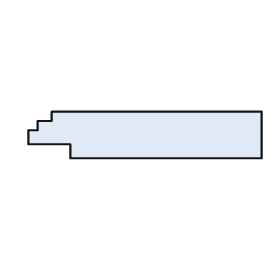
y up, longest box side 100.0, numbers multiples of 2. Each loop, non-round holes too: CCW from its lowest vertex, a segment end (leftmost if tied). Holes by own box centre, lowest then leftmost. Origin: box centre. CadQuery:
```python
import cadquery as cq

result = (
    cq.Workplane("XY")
    .moveTo(-32.0, -10.0)
    .lineTo(50.0, -10.0)
    .lineTo(50.0, 10.0)
    .lineTo(-40.0, 10.0)
    .lineTo(-40.0, 6.0)
    .lineTo(-46.0, 6.0)
    .lineTo(-46.0, 2.0)
    .lineTo(-50.0, 2.0)
    .lineTo(-50.0, -4.0)
    .lineTo(-32.0, -4.0)
    .close()
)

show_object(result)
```